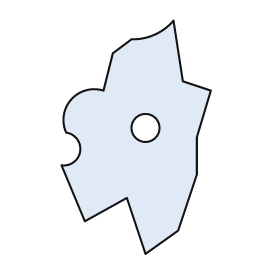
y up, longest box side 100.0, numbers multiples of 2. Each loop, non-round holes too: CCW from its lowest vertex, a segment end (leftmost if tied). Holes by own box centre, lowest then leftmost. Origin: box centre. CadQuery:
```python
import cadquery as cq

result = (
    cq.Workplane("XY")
    .moveTo(4.0, -50.0)
    .lineTo(18.0, -40.0)
    .lineTo(26.0, -16.0)
    .lineTo(26.0, 0.0)
    .lineTo(32.0, 20.0)
    .lineTo(20.0, 24.0)
    .lineTo(16.0, 50.0)
    .threePointArc((8.0, 44.0), (-2.0, 42.0))
    .lineTo(-10.0, 36.0)
    .lineTo(-14.0, 20.0)
    .threePointArc((-28.0, 16.0), (-30.0, 2.0))
    .threePointArc((-24.0, -6.0), (-32.0, -12.0))
    .lineTo(-22.0, -36.0)
    .lineTo(-4.0, -26.0)
    .close()
    .moveTo(4.0, 4.0)
    .circle(6.0)
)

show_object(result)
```